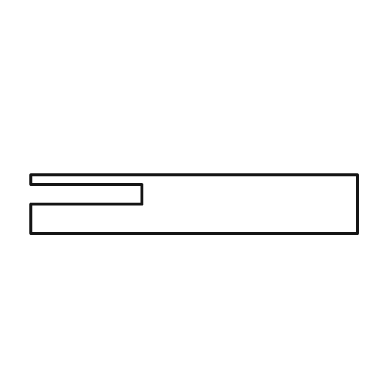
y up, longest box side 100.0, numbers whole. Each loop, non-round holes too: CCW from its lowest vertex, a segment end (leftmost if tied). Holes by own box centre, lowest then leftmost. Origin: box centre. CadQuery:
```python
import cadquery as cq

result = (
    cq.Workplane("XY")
    .moveTo(-50.0, -9.0)
    .lineTo(50.0, -9.0)
    .lineTo(50.0, 9.0)
    .lineTo(-50.0, 9.0)
    .lineTo(-50.0, 6.0)
    .lineTo(-16.0, 6.0)
    .lineTo(-16.0, 0.0)
    .lineTo(-50.0, 0.0)
    .close()
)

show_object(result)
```